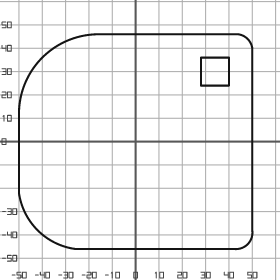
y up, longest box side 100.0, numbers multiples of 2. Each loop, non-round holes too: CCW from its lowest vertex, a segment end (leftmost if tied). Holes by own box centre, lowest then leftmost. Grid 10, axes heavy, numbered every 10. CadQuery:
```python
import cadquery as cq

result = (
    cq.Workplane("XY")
    .moveTo(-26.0, -46.0)
    .lineTo(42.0, -46.0)
    .threePointArc((48.0, -44.0), (50.0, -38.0))
    .lineTo(50.0, 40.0)
    .threePointArc((48.0, 44.0), (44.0, 46.0))
    .lineTo(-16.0, 46.0)
    .threePointArc((-40.0, 36.0), (-50.0, 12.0))
    .lineTo(-50.0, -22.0)
    .threePointArc((-42.0, -38.0), (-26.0, -46.0))
    .close()
    .moveTo(28.0, 24.0)
    .lineTo(40.0, 24.0)
    .lineTo(40.0, 36.0)
    .lineTo(28.0, 36.0)
    .close()
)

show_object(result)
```